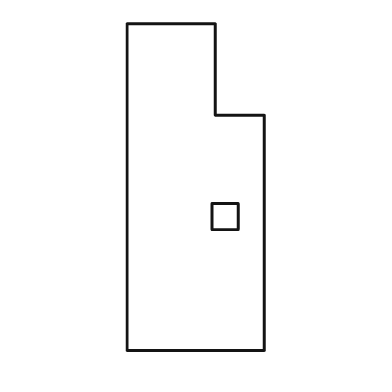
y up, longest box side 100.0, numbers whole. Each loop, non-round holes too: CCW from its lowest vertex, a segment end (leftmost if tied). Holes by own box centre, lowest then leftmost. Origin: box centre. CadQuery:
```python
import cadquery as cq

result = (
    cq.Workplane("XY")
    .moveTo(-21.0, -50.0)
    .lineTo(21.0, -50.0)
    .lineTo(21.0, 22.0)
    .lineTo(6.0, 22.0)
    .lineTo(6.0, 50.0)
    .lineTo(-21.0, 50.0)
    .close()
    .moveTo(5.0, -13.0)
    .lineTo(13.0, -13.0)
    .lineTo(13.0, -5.0)
    .lineTo(5.0, -5.0)
    .close()
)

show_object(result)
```